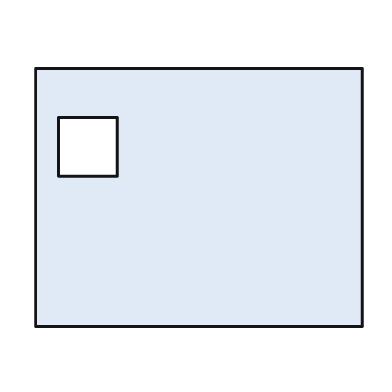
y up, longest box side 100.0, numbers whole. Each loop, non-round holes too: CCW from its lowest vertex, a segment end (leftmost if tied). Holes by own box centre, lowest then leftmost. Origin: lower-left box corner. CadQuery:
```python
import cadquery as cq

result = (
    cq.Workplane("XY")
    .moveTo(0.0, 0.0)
    .lineTo(100.0, 0.0)
    .lineTo(100.0, 79.0)
    .lineTo(0.0, 79.0)
    .close()
    .moveTo(7.0, 46.0)
    .lineTo(25.0, 46.0)
    .lineTo(25.0, 64.0)
    .lineTo(7.0, 64.0)
    .close()
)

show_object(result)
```